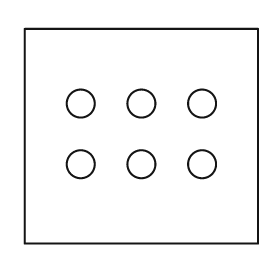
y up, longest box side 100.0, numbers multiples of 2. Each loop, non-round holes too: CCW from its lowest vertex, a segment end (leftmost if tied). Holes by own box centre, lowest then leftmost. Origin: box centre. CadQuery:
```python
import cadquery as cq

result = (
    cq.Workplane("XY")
    .moveTo(-50.0, -46.0)
    .lineTo(50.0, -46.0)
    .lineTo(50.0, 46.0)
    .lineTo(-50.0, 46.0)
    .close()
    .moveTo(-26.0, -12.0)
    .circle(6.0)
    .moveTo(0.0, -12.0)
    .circle(6.0)
    .moveTo(26.0, -12.0)
    .circle(6.0)
    .moveTo(-26.0, 14.0)
    .circle(6.0)
    .moveTo(0.0, 14.0)
    .circle(6.0)
    .moveTo(26.0, 14.0)
    .circle(6.0)
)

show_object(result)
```